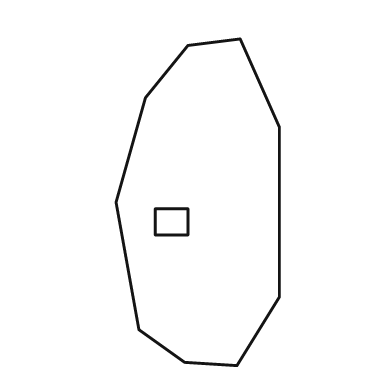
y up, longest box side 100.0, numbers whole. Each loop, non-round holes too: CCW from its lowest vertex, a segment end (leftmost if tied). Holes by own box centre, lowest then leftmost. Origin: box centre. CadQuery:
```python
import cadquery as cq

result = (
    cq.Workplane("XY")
    .moveTo(12.0, -50.0)
    .lineTo(25.0, -29.0)
    .lineTo(25.0, 23.0)
    .lineTo(13.0, 50.0)
    .lineTo(-3.0, 48.0)
    .lineTo(-16.0, 32.0)
    .lineTo(-25.0, 0.0)
    .lineTo(-18.0, -39.0)
    .lineTo(-4.0, -49.0)
    .close()
    .moveTo(-13.0, -10.0)
    .lineTo(-3.0, -10.0)
    .lineTo(-3.0, -2.0)
    .lineTo(-13.0, -2.0)
    .close()
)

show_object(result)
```